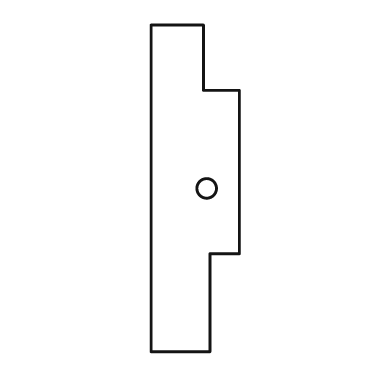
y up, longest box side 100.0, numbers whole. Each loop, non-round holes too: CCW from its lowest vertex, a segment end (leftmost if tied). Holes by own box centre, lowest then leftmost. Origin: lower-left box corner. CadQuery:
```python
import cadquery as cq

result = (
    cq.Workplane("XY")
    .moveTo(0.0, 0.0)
    .lineTo(18.0, 0.0)
    .lineTo(18.0, 30.0)
    .lineTo(27.0, 30.0)
    .lineTo(27.0, 80.0)
    .lineTo(16.0, 80.0)
    .lineTo(16.0, 100.0)
    .lineTo(0.0, 100.0)
    .close()
    .moveTo(17.0, 50.0)
    .circle(3.0)
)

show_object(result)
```